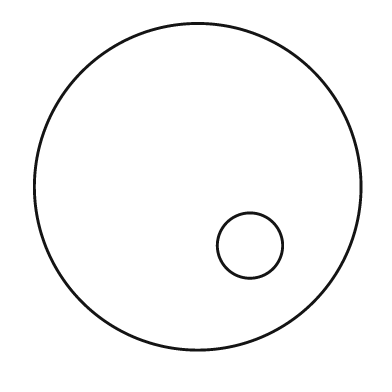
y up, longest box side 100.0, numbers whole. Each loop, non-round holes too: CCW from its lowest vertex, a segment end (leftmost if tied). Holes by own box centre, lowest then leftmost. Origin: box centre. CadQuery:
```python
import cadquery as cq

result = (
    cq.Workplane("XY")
    .moveTo(0.0, 0.0)
    .circle(50.0)
    .moveTo(16.0, -18.0)
    .circle(10.0)
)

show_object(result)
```